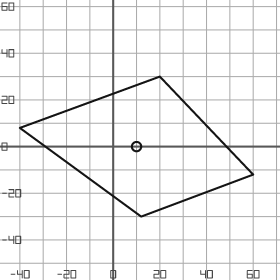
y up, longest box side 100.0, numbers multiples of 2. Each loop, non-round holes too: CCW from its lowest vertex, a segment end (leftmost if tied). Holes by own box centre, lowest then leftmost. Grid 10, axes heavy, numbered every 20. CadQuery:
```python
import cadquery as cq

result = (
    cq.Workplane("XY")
    .moveTo(12.0, -30.0)
    .lineTo(60.0, -12.0)
    .lineTo(20.0, 30.0)
    .lineTo(-40.0, 8.0)
    .close()
    .moveTo(10.0, 0.0)
    .circle(2.0)
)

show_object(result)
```